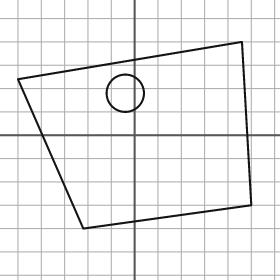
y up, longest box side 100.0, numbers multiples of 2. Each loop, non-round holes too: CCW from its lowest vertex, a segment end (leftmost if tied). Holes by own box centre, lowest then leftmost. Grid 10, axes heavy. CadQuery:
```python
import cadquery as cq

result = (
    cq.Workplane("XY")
    .moveTo(-22.0, -40.0)
    .lineTo(50.0, -30.0)
    .lineTo(46.0, 40.0)
    .lineTo(-50.0, 24.0)
    .close()
    .moveTo(-4.0, 18.0)
    .circle(8.0)
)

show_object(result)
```